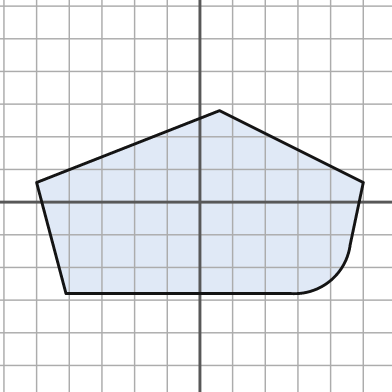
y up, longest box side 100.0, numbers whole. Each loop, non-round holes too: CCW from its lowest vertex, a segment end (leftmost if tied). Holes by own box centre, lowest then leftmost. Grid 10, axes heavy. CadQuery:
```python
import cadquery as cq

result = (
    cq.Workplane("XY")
    .moveTo(-41.0, -28.0)
    .lineTo(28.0, -28.0)
    .threePointArc((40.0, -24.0), (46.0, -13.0))
    .lineTo(50.0, 6.0)
    .lineTo(6.0, 28.0)
    .lineTo(-50.0, 6.0)
    .close()
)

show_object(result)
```